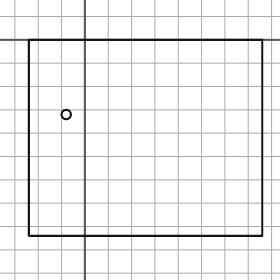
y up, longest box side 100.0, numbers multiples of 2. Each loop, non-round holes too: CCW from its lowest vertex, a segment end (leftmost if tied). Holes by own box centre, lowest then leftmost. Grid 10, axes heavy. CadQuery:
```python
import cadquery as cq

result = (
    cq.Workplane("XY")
    .moveTo(-24.0, -84.0)
    .lineTo(76.0, -84.0)
    .lineTo(76.0, 0.0)
    .lineTo(-24.0, 0.0)
    .close()
    .moveTo(-8.0, -32.0)
    .circle(2.0)
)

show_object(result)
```